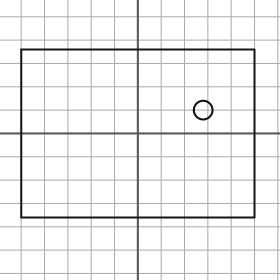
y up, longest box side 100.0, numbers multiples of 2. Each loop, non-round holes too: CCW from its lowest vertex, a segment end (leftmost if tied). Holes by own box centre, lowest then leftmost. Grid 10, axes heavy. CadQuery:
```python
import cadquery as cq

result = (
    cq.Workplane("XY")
    .moveTo(-50.0, -36.0)
    .lineTo(50.0, -36.0)
    .lineTo(50.0, 36.0)
    .lineTo(-50.0, 36.0)
    .close()
    .moveTo(28.0, 10.0)
    .circle(4.0)
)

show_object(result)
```